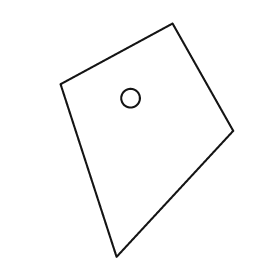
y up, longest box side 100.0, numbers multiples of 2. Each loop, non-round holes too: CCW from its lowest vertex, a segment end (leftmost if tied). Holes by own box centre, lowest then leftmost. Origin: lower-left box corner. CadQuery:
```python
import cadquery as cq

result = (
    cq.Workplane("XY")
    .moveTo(24.0, 0.0)
    .lineTo(74.0, 54.0)
    .lineTo(48.0, 100.0)
    .lineTo(0.0, 74.0)
    .close()
    .moveTo(30.0, 68.0)
    .circle(4.0)
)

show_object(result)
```